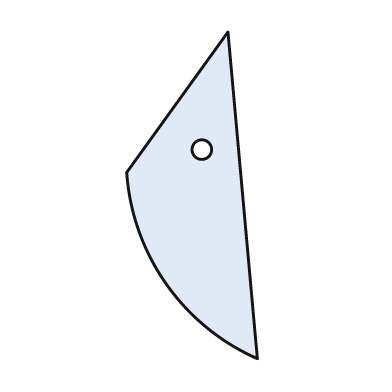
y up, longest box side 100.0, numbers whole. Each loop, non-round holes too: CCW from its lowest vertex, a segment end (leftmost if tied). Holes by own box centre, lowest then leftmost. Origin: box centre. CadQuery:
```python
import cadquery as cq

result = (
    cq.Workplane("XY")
    .moveTo(20.0, -50.0)
    .lineTo(11.0, 50.0)
    .lineTo(-20.0, 7.0)
    .threePointArc((-8.0, -27.0), (20.0, -50.0))
    .close()
    .moveTo(3.0, 14.0)
    .circle(3.0)
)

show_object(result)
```